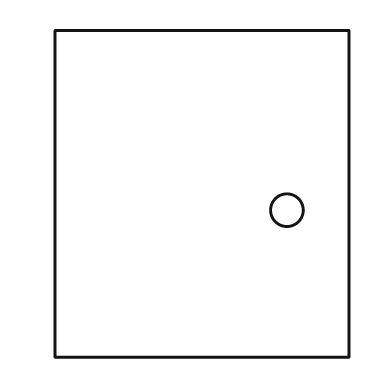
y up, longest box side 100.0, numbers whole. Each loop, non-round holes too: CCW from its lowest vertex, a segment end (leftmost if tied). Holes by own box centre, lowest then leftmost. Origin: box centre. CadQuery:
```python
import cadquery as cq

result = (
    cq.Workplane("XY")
    .moveTo(-45.0, -50.0)
    .lineTo(45.0, -50.0)
    .lineTo(45.0, 50.0)
    .lineTo(-45.0, 50.0)
    .close()
    .moveTo(26.0, -5.0)
    .circle(5.0)
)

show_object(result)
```